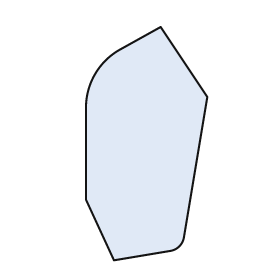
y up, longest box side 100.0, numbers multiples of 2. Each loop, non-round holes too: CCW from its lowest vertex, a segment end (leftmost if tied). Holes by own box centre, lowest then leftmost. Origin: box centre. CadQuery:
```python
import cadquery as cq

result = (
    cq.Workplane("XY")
    .moveTo(-14.0, -50.0)
    .lineTo(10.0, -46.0)
    .threePointArc((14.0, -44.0), (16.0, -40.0))
    .lineTo(26.0, 20.0)
    .lineTo(6.0, 50.0)
    .lineTo(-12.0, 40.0)
    .threePointArc((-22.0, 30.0), (-26.0, 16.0))
    .lineTo(-26.0, -24.0)
    .close()
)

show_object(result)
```